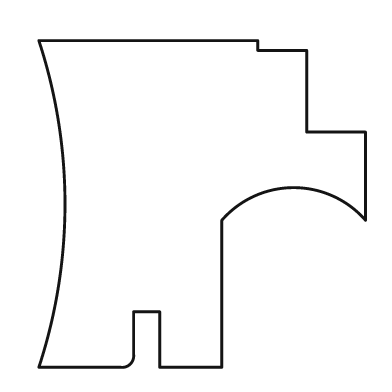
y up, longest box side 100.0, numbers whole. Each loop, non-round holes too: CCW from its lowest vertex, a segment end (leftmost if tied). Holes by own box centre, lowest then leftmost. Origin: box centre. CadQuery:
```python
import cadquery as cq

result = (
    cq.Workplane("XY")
    .moveTo(-50.0, -50.0)
    .lineTo(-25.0, -50.0)
    .threePointArc((-22.0, -49.0), (-21.0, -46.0))
    .lineTo(-21.0, -33.0)
    .lineTo(-13.0, -33.0)
    .lineTo(-13.0, -50.0)
    .lineTo(6.0, -50.0)
    .lineTo(6.0, -5.0)
    .threePointArc((28.0, 5.0), (50.0, -5.0))
    .lineTo(50.0, 22.0)
    .lineTo(32.0, 22.0)
    .lineTo(32.0, 47.0)
    .lineTo(17.0, 47.0)
    .lineTo(17.0, 50.0)
    .lineTo(-50.0, 50.0)
    .threePointArc((-42.0, 0.0), (-50.0, -50.0))
    .close()
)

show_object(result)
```